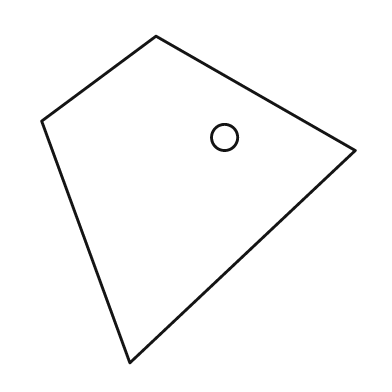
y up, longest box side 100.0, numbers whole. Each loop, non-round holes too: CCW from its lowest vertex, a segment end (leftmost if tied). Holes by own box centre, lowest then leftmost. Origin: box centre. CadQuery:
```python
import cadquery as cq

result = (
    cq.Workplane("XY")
    .moveTo(-21.0, -50.0)
    .lineTo(48.0, 15.0)
    .lineTo(-13.0, 50.0)
    .lineTo(-48.0, 24.0)
    .close()
    .moveTo(8.0, 19.0)
    .circle(4.0)
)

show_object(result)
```